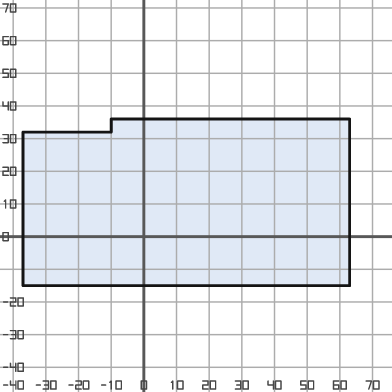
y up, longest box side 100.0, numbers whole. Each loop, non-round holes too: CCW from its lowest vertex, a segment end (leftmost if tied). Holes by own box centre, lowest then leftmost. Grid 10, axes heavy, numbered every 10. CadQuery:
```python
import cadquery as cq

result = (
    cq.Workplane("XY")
    .moveTo(-37.0, -15.0)
    .lineTo(63.0, -15.0)
    .lineTo(63.0, 36.0)
    .lineTo(-10.0, 36.0)
    .lineTo(-10.0, 32.0)
    .lineTo(-37.0, 32.0)
    .close()
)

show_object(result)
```